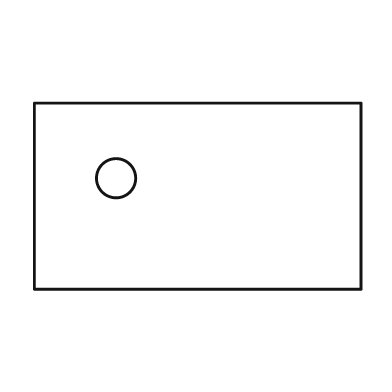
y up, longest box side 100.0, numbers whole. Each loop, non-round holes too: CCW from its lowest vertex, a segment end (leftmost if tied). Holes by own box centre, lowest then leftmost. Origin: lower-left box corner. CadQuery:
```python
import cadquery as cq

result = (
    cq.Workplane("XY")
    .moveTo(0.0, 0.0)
    .lineTo(100.0, 0.0)
    .lineTo(100.0, 57.0)
    .lineTo(0.0, 57.0)
    .close()
    .moveTo(25.0, 34.0)
    .circle(6.0)
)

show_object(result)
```